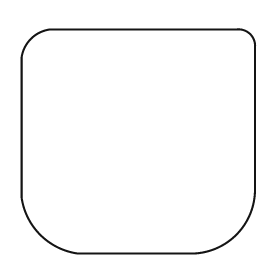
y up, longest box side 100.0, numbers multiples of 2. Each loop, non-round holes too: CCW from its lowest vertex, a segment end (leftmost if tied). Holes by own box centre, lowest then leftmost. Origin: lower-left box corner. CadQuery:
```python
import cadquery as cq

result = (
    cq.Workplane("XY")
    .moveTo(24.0, 0.0)
    .lineTo(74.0, 0.0)
    .threePointArc((92.0, 8.0), (100.0, 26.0))
    .lineTo(100.0, 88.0)
    .threePointArc((98.0, 94.0), (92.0, 96.0))
    .lineTo(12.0, 96.0)
    .threePointArc((4.0, 92.0), (0.0, 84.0))
    .lineTo(0.0, 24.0)
    .threePointArc((8.0, 8.0), (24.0, 0.0))
    .close()
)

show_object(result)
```